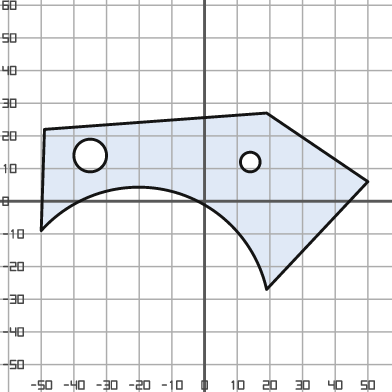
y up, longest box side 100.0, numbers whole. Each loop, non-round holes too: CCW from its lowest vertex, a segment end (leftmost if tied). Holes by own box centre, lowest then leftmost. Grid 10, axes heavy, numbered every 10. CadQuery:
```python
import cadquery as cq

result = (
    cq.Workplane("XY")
    .moveTo(19.0, -27.0)
    .lineTo(50.0, 6.0)
    .lineTo(19.0, 27.0)
    .lineTo(-49.0, 22.0)
    .lineTo(-50.0, -9.0)
    .threePointArc((-10.0, 3.0), (19.0, -27.0))
    .close()
    .moveTo(14.0, 12.0)
    .circle(3.0)
    .moveTo(-35.0, 14.0)
    .circle(5.0)
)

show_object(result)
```